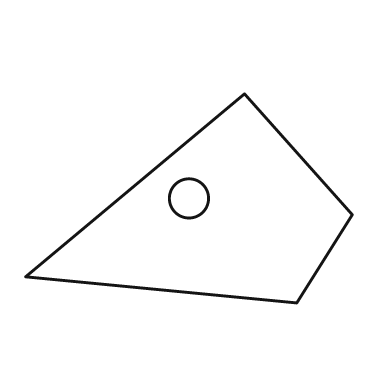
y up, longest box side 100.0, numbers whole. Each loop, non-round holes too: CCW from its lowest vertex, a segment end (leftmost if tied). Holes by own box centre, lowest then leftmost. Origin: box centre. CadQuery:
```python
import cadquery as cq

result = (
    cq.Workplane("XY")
    .moveTo(33.0, -32.0)
    .lineTo(50.0, -5.0)
    .lineTo(17.0, 32.0)
    .lineTo(-50.0, -24.0)
    .close()
    .moveTo(0.0, 0.0)
    .circle(6.0)
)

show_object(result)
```